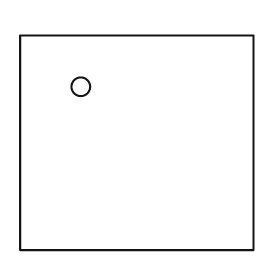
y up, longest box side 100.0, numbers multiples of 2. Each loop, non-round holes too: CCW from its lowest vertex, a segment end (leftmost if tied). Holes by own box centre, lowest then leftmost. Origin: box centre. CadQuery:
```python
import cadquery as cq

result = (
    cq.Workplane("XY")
    .moveTo(-50.0, -46.0)
    .lineTo(50.0, -46.0)
    .lineTo(50.0, 46.0)
    .lineTo(-50.0, 46.0)
    .close()
    .moveTo(-24.0, 24.0)
    .circle(4.0)
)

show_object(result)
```